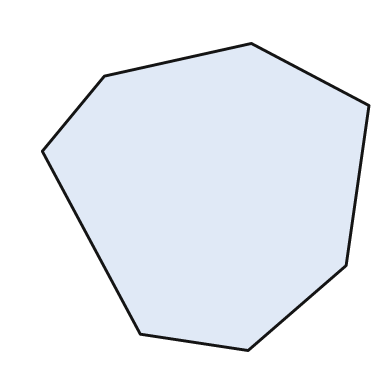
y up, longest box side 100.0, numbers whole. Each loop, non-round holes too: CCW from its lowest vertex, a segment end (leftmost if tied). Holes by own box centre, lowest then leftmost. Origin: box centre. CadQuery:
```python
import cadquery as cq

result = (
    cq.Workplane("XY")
    .moveTo(13.0, -47.0)
    .lineTo(43.0, -21.0)
    .lineTo(50.0, 28.0)
    .lineTo(14.0, 47.0)
    .lineTo(-31.0, 37.0)
    .lineTo(-50.0, 14.0)
    .lineTo(-20.0, -42.0)
    .close()
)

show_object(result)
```